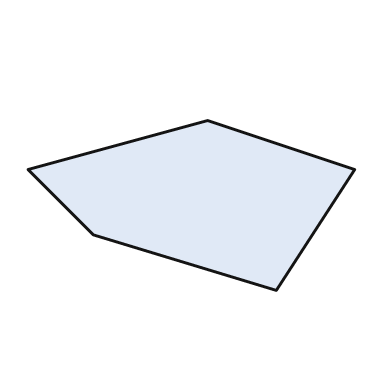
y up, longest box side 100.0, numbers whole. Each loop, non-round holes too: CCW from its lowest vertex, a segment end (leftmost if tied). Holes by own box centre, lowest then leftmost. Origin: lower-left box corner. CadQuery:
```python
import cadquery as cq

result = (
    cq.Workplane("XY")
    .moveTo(76.0, 0.0)
    .lineTo(100.0, 37.0)
    .lineTo(55.0, 52.0)
    .lineTo(0.0, 37.0)
    .lineTo(20.0, 17.0)
    .close()
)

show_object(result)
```